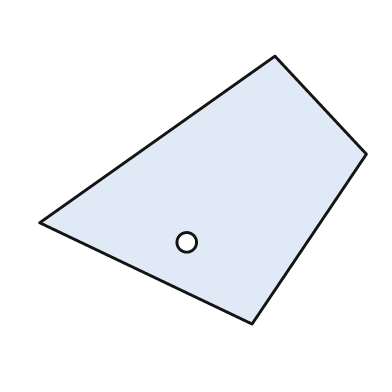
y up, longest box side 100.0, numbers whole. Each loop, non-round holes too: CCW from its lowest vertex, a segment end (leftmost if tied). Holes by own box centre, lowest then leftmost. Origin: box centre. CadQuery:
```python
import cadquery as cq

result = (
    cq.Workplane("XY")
    .moveTo(15.0, -41.0)
    .lineTo(50.0, 11.0)
    .lineTo(22.0, 41.0)
    .lineTo(-50.0, -10.0)
    .close()
    .moveTo(-5.0, -16.0)
    .circle(3.0)
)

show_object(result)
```